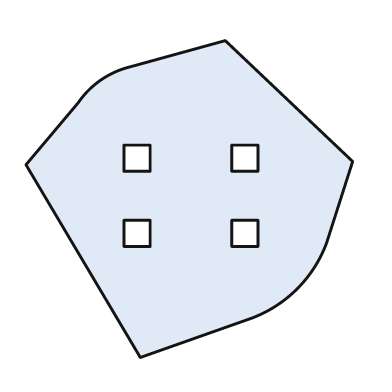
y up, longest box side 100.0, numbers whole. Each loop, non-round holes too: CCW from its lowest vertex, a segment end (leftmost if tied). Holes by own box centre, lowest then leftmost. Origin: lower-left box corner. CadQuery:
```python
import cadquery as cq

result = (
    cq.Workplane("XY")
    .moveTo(35.0, 0.0)
    .lineTo(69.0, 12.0)
    .threePointArc((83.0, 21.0), (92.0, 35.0))
    .lineTo(100.0, 60.0)
    .lineTo(61.0, 97.0)
    .lineTo(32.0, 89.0)
    .threePointArc((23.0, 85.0), (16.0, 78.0))
    .lineTo(0.0, 59.0)
    .close()
    .moveTo(30.0, 34.0)
    .lineTo(38.0, 34.0)
    .lineTo(38.0, 42.0)
    .lineTo(30.0, 42.0)
    .close()
    .moveTo(63.0, 34.0)
    .lineTo(71.0, 34.0)
    .lineTo(71.0, 42.0)
    .lineTo(63.0, 42.0)
    .close()
    .moveTo(30.0, 57.0)
    .lineTo(38.0, 57.0)
    .lineTo(38.0, 65.0)
    .lineTo(30.0, 65.0)
    .close()
    .moveTo(63.0, 57.0)
    .lineTo(71.0, 57.0)
    .lineTo(71.0, 65.0)
    .lineTo(63.0, 65.0)
    .close()
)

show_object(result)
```